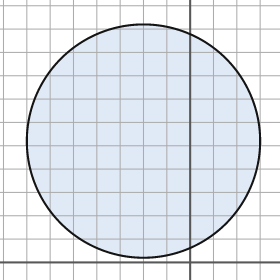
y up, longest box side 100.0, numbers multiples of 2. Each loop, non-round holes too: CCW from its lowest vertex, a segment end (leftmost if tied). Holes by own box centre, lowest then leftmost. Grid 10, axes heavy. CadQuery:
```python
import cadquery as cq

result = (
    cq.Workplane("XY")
    .moveTo(-20.0, 52.0)
    .circle(50.0)
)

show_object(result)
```